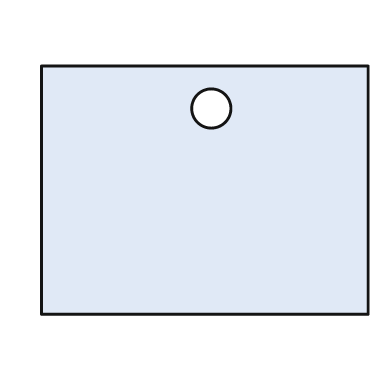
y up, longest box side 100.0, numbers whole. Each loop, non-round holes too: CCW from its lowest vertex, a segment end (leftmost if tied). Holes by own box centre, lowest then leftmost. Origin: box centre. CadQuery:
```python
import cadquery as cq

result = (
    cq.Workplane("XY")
    .moveTo(-50.0, -38.0)
    .lineTo(50.0, -38.0)
    .lineTo(50.0, 38.0)
    .lineTo(-50.0, 38.0)
    .close()
    .moveTo(2.0, 25.0)
    .circle(6.0)
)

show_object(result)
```